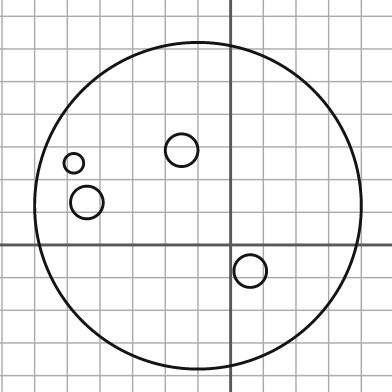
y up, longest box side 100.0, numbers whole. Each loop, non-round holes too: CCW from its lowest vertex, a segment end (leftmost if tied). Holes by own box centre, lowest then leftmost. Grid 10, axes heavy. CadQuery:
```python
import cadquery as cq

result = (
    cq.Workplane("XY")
    .moveTo(-10.0, 12.0)
    .circle(50.0)
    .moveTo(6.0, -8.0)
    .circle(5.0)
    .moveTo(-44.0, 13.0)
    .circle(5.0)
    .moveTo(-48.0, 25.0)
    .circle(3.0)
    .moveTo(-15.0, 29.0)
    .circle(5.0)
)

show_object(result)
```